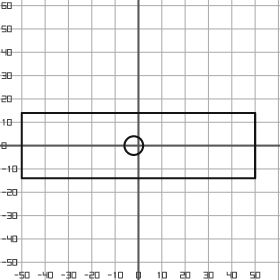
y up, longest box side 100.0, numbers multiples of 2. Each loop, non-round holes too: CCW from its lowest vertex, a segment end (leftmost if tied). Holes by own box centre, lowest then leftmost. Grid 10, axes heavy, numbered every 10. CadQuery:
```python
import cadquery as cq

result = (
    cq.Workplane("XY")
    .moveTo(-50.0, -14.0)
    .lineTo(50.0, -14.0)
    .lineTo(50.0, 14.0)
    .lineTo(-50.0, 14.0)
    .close()
    .moveTo(-2.0, 0.0)
    .circle(4.0)
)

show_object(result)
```